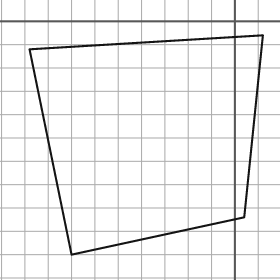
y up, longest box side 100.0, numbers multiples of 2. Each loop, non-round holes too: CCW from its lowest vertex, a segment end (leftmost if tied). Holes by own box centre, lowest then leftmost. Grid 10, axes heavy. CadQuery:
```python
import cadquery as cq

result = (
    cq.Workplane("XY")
    .moveTo(-70.0, -100.0)
    .lineTo(4.0, -84.0)
    .lineTo(12.0, -6.0)
    .lineTo(-88.0, -12.0)
    .close()
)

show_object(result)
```